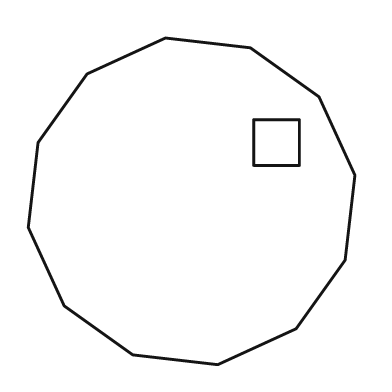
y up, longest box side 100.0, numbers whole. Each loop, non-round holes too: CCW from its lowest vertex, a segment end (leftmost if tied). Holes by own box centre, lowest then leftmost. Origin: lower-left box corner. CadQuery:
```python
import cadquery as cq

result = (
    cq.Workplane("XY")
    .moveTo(58.0, 0.0)
    .lineTo(82.0, 11.0)
    .lineTo(97.0, 32.0)
    .lineTo(100.0, 58.0)
    .lineTo(89.0, 82.0)
    .lineTo(68.0, 97.0)
    .lineTo(42.0, 100.0)
    .lineTo(18.0, 89.0)
    .lineTo(3.0, 68.0)
    .lineTo(0.0, 42.0)
    .lineTo(11.0, 18.0)
    .lineTo(32.0, 3.0)
    .close()
    .moveTo(69.0, 61.0)
    .lineTo(83.0, 61.0)
    .lineTo(83.0, 75.0)
    .lineTo(69.0, 75.0)
    .close()
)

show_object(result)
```